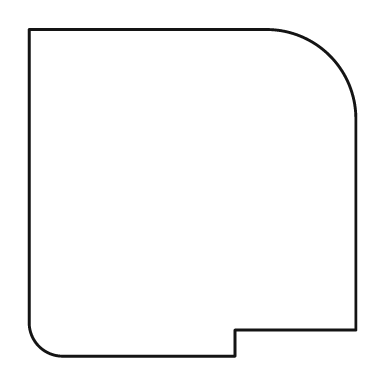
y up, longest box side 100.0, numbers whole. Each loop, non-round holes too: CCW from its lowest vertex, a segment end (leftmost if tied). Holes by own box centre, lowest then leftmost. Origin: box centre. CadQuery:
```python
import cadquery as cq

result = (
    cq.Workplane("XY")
    .moveTo(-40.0, -50.0)
    .lineTo(13.0, -50.0)
    .lineTo(13.0, -42.0)
    .lineTo(50.0, -42.0)
    .lineTo(50.0, 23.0)
    .threePointArc((42.0, 42.0), (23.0, 50.0))
    .lineTo(-50.0, 50.0)
    .lineTo(-50.0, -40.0)
    .threePointArc((-47.0, -47.0), (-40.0, -50.0))
    .close()
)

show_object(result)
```